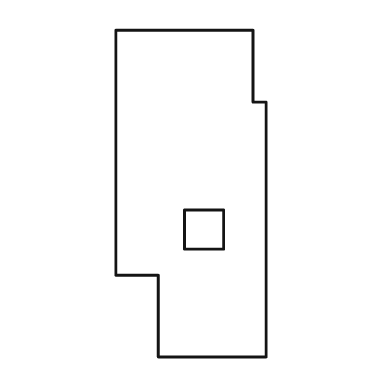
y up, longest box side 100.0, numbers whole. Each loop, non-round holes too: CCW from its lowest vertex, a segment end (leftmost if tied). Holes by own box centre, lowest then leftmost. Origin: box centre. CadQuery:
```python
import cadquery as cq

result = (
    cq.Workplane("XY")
    .moveTo(-10.0, -50.0)
    .lineTo(23.0, -50.0)
    .lineTo(23.0, 28.0)
    .lineTo(19.0, 28.0)
    .lineTo(19.0, 50.0)
    .lineTo(-23.0, 50.0)
    .lineTo(-23.0, -25.0)
    .lineTo(-10.0, -25.0)
    .close()
    .moveTo(-2.0, -17.0)
    .lineTo(10.0, -17.0)
    .lineTo(10.0, -5.0)
    .lineTo(-2.0, -5.0)
    .close()
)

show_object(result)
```